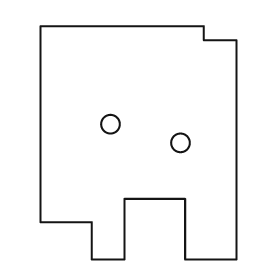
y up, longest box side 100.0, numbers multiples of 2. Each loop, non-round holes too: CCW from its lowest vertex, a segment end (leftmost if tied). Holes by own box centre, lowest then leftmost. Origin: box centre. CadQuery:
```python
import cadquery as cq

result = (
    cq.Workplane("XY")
    .moveTo(-20.0, -50.0)
    .lineTo(-6.0, -50.0)
    .lineTo(-6.0, -24.0)
    .lineTo(20.0, -24.0)
    .lineTo(20.0, -50.0)
    .lineTo(42.0, -50.0)
    .lineTo(42.0, 44.0)
    .lineTo(28.0, 44.0)
    .lineTo(28.0, 50.0)
    .lineTo(-42.0, 50.0)
    .lineTo(-42.0, -34.0)
    .lineTo(-20.0, -34.0)
    .close()
    .moveTo(18.0, 0.0)
    .circle(4.0)
    .moveTo(-12.0, 8.0)
    .circle(4.0)
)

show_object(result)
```